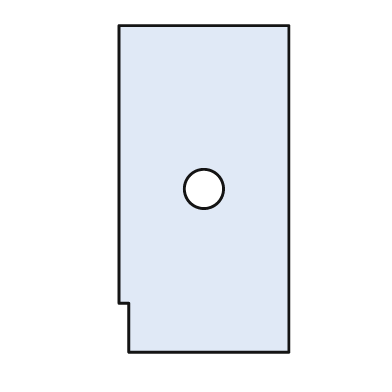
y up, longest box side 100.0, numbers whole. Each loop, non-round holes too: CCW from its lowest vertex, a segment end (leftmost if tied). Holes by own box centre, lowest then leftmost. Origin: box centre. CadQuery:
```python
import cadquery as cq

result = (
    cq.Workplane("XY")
    .moveTo(-23.0, -50.0)
    .lineTo(26.0, -50.0)
    .lineTo(26.0, 50.0)
    .lineTo(-26.0, 50.0)
    .lineTo(-26.0, -35.0)
    .lineTo(-23.0, -35.0)
    .close()
    .moveTo(0.0, 0.0)
    .circle(6.0)
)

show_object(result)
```